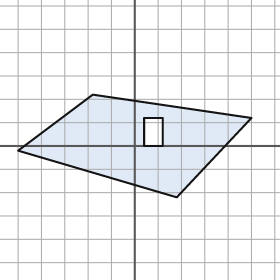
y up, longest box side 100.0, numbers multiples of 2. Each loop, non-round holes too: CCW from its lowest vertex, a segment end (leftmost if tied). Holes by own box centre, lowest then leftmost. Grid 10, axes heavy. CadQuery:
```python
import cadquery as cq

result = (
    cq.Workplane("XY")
    .moveTo(18.0, -22.0)
    .lineTo(50.0, 12.0)
    .lineTo(-18.0, 22.0)
    .lineTo(-50.0, -2.0)
    .close()
    .moveTo(4.0, 0.0)
    .lineTo(12.0, 0.0)
    .lineTo(12.0, 12.0)
    .lineTo(4.0, 12.0)
    .close()
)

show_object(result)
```